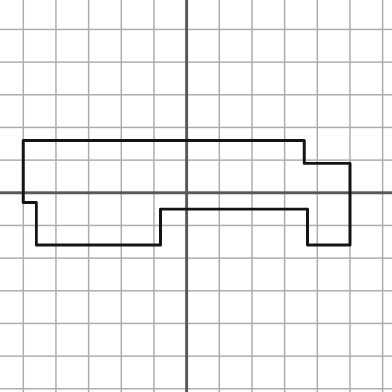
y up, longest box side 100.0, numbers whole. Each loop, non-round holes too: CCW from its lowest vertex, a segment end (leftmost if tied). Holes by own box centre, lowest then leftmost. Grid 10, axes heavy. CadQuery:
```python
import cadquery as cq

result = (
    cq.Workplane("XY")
    .moveTo(-46.0, -16.0)
    .lineTo(-8.0, -16.0)
    .lineTo(-8.0, -5.0)
    .lineTo(37.0, -5.0)
    .lineTo(37.0, -16.0)
    .lineTo(50.0, -16.0)
    .lineTo(50.0, 9.0)
    .lineTo(36.0, 9.0)
    .lineTo(36.0, 16.0)
    .lineTo(-50.0, 16.0)
    .lineTo(-50.0, -3.0)
    .lineTo(-46.0, -3.0)
    .close()
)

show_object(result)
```